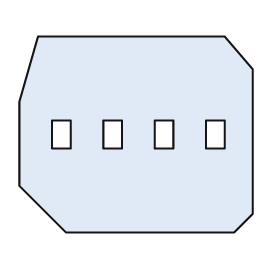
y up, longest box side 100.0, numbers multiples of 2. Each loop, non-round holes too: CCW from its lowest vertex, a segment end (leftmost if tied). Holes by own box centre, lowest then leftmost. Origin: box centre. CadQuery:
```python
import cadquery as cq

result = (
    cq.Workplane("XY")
    .moveTo(-30.0, -42.0)
    .lineTo(42.0, -42.0)
    .lineTo(50.0, -34.0)
    .lineTo(50.0, 28.0)
    .lineTo(38.0, 42.0)
    .lineTo(-42.0, 42.0)
    .lineTo(-50.0, 14.0)
    .lineTo(-50.0, -22.0)
    .close()
    .moveTo(-36.0, -6.0)
    .lineTo(-28.0, -6.0)
    .lineTo(-28.0, 6.0)
    .lineTo(-36.0, 6.0)
    .close()
    .moveTo(-14.0, -6.0)
    .lineTo(-6.0, -6.0)
    .lineTo(-6.0, 6.0)
    .lineTo(-14.0, 6.0)
    .close()
    .moveTo(8.0, -6.0)
    .lineTo(16.0, -6.0)
    .lineTo(16.0, 6.0)
    .lineTo(8.0, 6.0)
    .close()
    .moveTo(30.0, -6.0)
    .lineTo(38.0, -6.0)
    .lineTo(38.0, 6.0)
    .lineTo(30.0, 6.0)
    .close()
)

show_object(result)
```